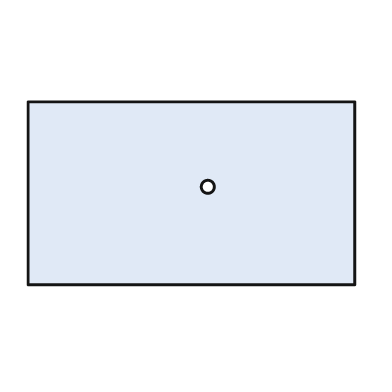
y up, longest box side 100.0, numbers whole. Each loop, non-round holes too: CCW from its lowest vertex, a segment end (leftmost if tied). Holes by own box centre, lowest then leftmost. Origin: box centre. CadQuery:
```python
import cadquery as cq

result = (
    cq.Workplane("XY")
    .moveTo(-50.0, -28.0)
    .lineTo(50.0, -28.0)
    .lineTo(50.0, 28.0)
    .lineTo(-50.0, 28.0)
    .close()
    .moveTo(5.0, 2.0)
    .circle(2.0)
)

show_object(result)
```